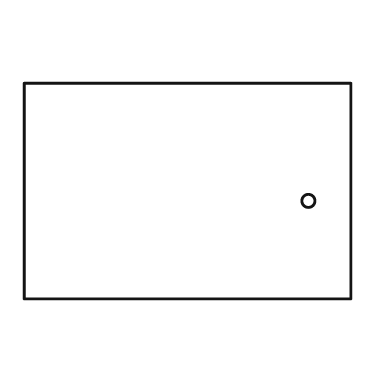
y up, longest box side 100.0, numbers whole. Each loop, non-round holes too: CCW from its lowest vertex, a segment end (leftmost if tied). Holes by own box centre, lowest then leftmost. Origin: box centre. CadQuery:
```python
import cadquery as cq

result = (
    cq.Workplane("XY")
    .moveTo(-50.0, -33.0)
    .lineTo(50.0, -33.0)
    .lineTo(50.0, 33.0)
    .lineTo(-50.0, 33.0)
    .close()
    .moveTo(37.0, -3.0)
    .circle(2.0)
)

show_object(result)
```